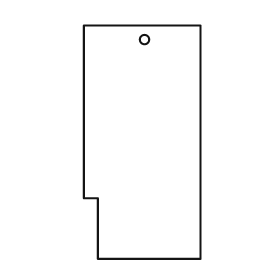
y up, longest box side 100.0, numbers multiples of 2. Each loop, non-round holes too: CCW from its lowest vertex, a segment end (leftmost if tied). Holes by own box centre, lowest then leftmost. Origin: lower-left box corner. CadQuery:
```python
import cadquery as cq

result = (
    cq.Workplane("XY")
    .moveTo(6.0, 0.0)
    .lineTo(50.0, 0.0)
    .lineTo(50.0, 100.0)
    .lineTo(0.0, 100.0)
    .lineTo(0.0, 26.0)
    .lineTo(6.0, 26.0)
    .close()
    .moveTo(26.0, 94.0)
    .circle(2.0)
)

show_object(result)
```